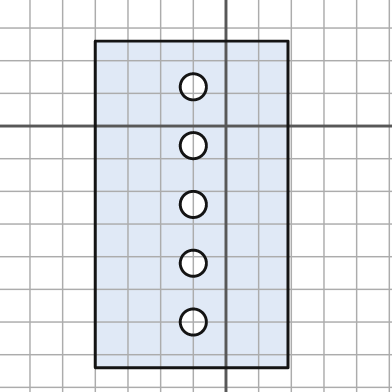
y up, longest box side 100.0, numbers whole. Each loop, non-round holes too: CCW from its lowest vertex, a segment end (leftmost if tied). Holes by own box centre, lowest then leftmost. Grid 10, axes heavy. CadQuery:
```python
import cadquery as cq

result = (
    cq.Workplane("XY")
    .moveTo(-40.0, -74.0)
    .lineTo(19.0, -74.0)
    .lineTo(19.0, 26.0)
    .lineTo(-40.0, 26.0)
    .close()
    .moveTo(-10.0, -60.0)
    .circle(4.0)
    .moveTo(-10.0, -42.0)
    .circle(4.0)
    .moveTo(-10.0, -24.0)
    .circle(4.0)
    .moveTo(-10.0, -6.0)
    .circle(4.0)
    .moveTo(-10.0, 12.0)
    .circle(4.0)
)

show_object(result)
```